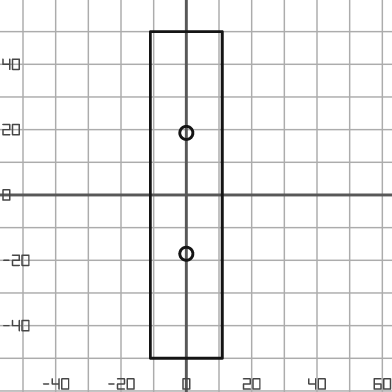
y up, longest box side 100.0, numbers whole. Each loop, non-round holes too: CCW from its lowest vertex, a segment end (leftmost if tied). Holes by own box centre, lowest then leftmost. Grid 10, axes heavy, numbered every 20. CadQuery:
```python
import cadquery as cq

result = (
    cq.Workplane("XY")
    .moveTo(-11.0, -50.0)
    .lineTo(11.0, -50.0)
    .lineTo(11.0, 50.0)
    .lineTo(-11.0, 50.0)
    .close()
    .moveTo(0.0, -18.0)
    .circle(2.0)
    .moveTo(0.0, 19.0)
    .circle(2.0)
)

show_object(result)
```